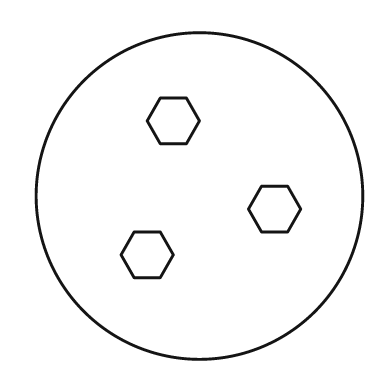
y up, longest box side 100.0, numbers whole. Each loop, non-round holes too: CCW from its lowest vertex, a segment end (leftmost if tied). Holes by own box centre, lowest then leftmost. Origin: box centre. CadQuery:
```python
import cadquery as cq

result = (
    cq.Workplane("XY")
    .moveTo(0.0, 0.0)
    .circle(50.0)
    .moveTo(-20.0, -25.0)
    .lineTo(-12.0, -25.0)
    .lineTo(-8.0, -18.0)
    .lineTo(-12.0, -11.0)
    .lineTo(-20.0, -11.0)
    .lineTo(-24.0, -18.0)
    .close()
    .moveTo(19.0, -11.0)
    .lineTo(27.0, -11.0)
    .lineTo(31.0, -4.0)
    .lineTo(27.0, 3.0)
    .lineTo(19.0, 3.0)
    .lineTo(15.0, -4.0)
    .close()
    .moveTo(-12.0, 16.0)
    .lineTo(-4.0, 16.0)
    .lineTo(0.0, 23.0)
    .lineTo(-4.0, 30.0)
    .lineTo(-12.0, 30.0)
    .lineTo(-16.0, 23.0)
    .close()
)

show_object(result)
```